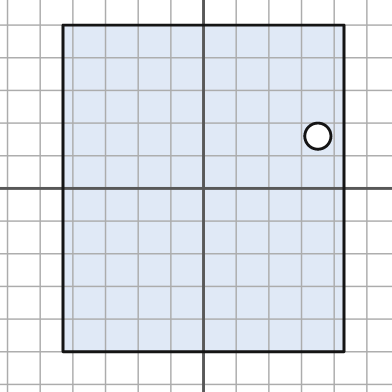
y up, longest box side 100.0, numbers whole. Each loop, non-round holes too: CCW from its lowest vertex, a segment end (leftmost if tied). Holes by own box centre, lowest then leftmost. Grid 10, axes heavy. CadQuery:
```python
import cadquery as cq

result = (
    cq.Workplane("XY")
    .moveTo(-43.0, -50.0)
    .lineTo(43.0, -50.0)
    .lineTo(43.0, 50.0)
    .lineTo(-43.0, 50.0)
    .close()
    .moveTo(35.0, 16.0)
    .circle(4.0)
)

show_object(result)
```